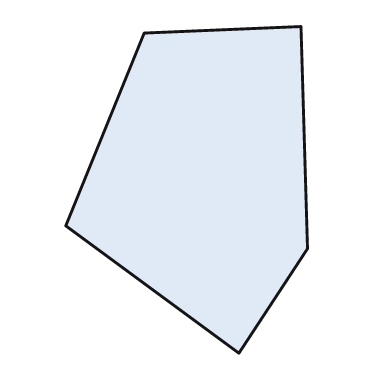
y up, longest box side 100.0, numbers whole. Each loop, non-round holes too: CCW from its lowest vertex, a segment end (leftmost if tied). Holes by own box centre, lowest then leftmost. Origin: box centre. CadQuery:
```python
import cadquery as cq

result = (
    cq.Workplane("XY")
    .moveTo(16.0, -50.0)
    .lineTo(37.0, -18.0)
    .lineTo(35.0, 50.0)
    .lineTo(-13.0, 48.0)
    .lineTo(-37.0, -11.0)
    .close()
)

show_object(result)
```